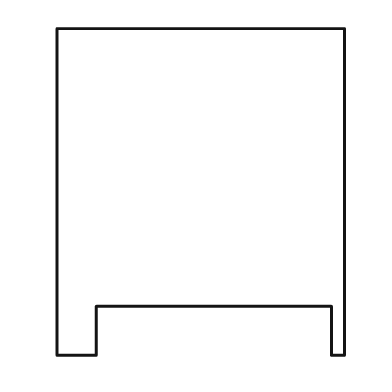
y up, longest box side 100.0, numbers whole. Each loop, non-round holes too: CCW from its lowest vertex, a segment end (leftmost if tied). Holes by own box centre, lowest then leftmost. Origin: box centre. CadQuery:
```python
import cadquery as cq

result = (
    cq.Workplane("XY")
    .moveTo(-44.0, -50.0)
    .lineTo(-32.0, -50.0)
    .lineTo(-32.0, -35.0)
    .lineTo(40.0, -35.0)
    .lineTo(40.0, -50.0)
    .lineTo(44.0, -50.0)
    .lineTo(44.0, 50.0)
    .lineTo(-44.0, 50.0)
    .close()
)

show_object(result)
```